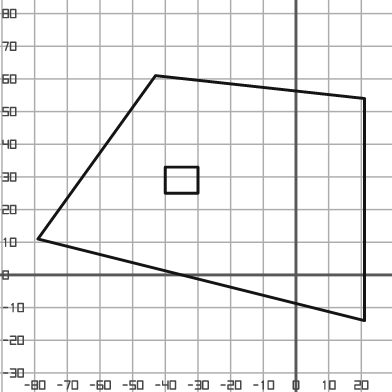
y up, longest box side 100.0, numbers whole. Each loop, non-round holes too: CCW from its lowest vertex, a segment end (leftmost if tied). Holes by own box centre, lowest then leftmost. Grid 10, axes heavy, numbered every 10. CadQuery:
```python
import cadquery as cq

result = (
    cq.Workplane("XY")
    .moveTo(21.0, -14.0)
    .lineTo(21.0, 54.0)
    .lineTo(-43.0, 61.0)
    .lineTo(-79.0, 11.0)
    .close()
    .moveTo(-40.0, 25.0)
    .lineTo(-30.0, 25.0)
    .lineTo(-30.0, 33.0)
    .lineTo(-40.0, 33.0)
    .close()
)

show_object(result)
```